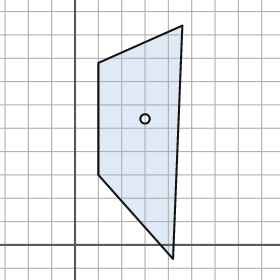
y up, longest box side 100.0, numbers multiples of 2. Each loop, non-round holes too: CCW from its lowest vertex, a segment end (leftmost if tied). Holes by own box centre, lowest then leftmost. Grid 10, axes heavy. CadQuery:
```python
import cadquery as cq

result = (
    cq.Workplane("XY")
    .moveTo(42.0, -6.0)
    .lineTo(46.0, 94.0)
    .lineTo(10.0, 78.0)
    .lineTo(10.0, 30.0)
    .close()
    .moveTo(30.0, 54.0)
    .circle(2.0)
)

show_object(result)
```